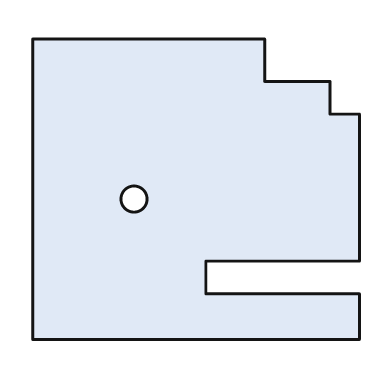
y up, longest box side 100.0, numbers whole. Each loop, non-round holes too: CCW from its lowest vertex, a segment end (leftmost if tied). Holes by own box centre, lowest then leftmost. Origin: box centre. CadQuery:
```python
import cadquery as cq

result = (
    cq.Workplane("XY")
    .moveTo(-50.0, -46.0)
    .lineTo(50.0, -46.0)
    .lineTo(50.0, -32.0)
    .lineTo(3.0, -32.0)
    .lineTo(3.0, -22.0)
    .lineTo(50.0, -22.0)
    .lineTo(50.0, 23.0)
    .lineTo(41.0, 23.0)
    .lineTo(41.0, 33.0)
    .lineTo(21.0, 33.0)
    .lineTo(21.0, 46.0)
    .lineTo(-50.0, 46.0)
    .close()
    .moveTo(-19.0, -3.0)
    .circle(4.0)
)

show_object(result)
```